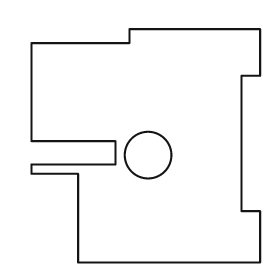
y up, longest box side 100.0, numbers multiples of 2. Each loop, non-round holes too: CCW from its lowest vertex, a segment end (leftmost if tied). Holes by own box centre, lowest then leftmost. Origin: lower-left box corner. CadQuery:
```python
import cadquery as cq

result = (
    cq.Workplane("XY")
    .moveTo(20.0, 0.0)
    .lineTo(98.0, 0.0)
    .lineTo(98.0, 22.0)
    .lineTo(90.0, 22.0)
    .lineTo(90.0, 80.0)
    .lineTo(98.0, 80.0)
    .lineTo(98.0, 100.0)
    .lineTo(42.0, 100.0)
    .lineTo(42.0, 94.0)
    .lineTo(0.0, 94.0)
    .lineTo(0.0, 52.0)
    .lineTo(36.0, 52.0)
    .lineTo(36.0, 42.0)
    .lineTo(0.0, 42.0)
    .lineTo(0.0, 38.0)
    .lineTo(20.0, 38.0)
    .close()
    .moveTo(50.0, 46.0)
    .circle(10.0)
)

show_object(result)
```